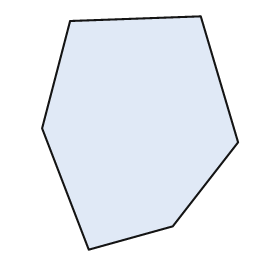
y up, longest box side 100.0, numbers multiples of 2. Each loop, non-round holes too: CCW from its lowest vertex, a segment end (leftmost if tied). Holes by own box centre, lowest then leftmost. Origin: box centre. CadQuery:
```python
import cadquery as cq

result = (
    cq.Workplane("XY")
    .moveTo(-22.0, -50.0)
    .lineTo(14.0, -40.0)
    .lineTo(42.0, -4.0)
    .lineTo(26.0, 50.0)
    .lineTo(-30.0, 48.0)
    .lineTo(-42.0, 2.0)
    .close()
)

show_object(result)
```